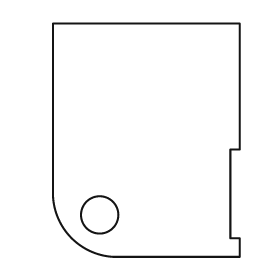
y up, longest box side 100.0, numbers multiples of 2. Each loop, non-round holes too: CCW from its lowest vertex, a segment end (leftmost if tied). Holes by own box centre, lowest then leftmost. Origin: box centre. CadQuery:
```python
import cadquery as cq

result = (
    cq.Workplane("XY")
    .moveTo(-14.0, -50.0)
    .lineTo(40.0, -50.0)
    .lineTo(40.0, -42.0)
    .lineTo(36.0, -42.0)
    .lineTo(36.0, -4.0)
    .lineTo(40.0, -4.0)
    .lineTo(40.0, 50.0)
    .lineTo(-40.0, 50.0)
    .lineTo(-40.0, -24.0)
    .threePointArc((-32.0, -42.0), (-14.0, -50.0))
    .close()
    .moveTo(-20.0, -32.0)
    .circle(8.0)
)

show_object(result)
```